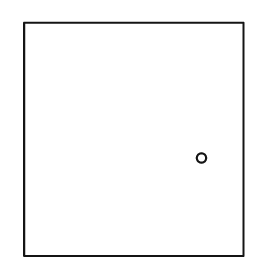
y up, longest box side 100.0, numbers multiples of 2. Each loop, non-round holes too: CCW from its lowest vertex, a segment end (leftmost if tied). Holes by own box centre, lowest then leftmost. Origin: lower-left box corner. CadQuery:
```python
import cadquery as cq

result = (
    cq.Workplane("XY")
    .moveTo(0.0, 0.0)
    .lineTo(94.0, 0.0)
    .lineTo(94.0, 100.0)
    .lineTo(0.0, 100.0)
    .close()
    .moveTo(76.0, 42.0)
    .circle(2.0)
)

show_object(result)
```